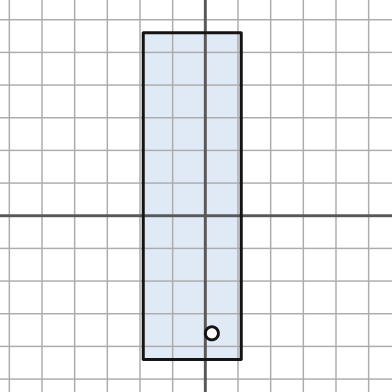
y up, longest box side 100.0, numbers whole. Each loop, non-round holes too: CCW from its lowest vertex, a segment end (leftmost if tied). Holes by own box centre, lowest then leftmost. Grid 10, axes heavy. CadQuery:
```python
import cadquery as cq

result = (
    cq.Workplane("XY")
    .moveTo(-19.0, -44.0)
    .lineTo(11.0, -44.0)
    .lineTo(11.0, 56.0)
    .lineTo(-19.0, 56.0)
    .close()
    .moveTo(2.0, -36.0)
    .circle(2.0)
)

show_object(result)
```